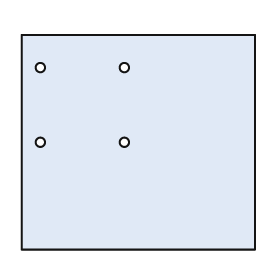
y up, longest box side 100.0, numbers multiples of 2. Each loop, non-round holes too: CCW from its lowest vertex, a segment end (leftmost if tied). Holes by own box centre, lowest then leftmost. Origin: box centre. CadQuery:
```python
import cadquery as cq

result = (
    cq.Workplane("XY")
    .moveTo(-50.0, -46.0)
    .lineTo(50.0, -46.0)
    .lineTo(50.0, 46.0)
    .lineTo(-50.0, 46.0)
    .close()
    .moveTo(-42.0, 0.0)
    .circle(2.0)
    .moveTo(-6.0, 0.0)
    .circle(2.0)
    .moveTo(-42.0, 32.0)
    .circle(2.0)
    .moveTo(-6.0, 32.0)
    .circle(2.0)
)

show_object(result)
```